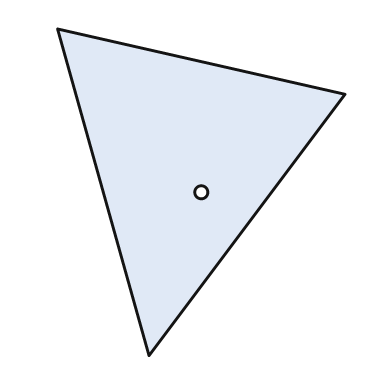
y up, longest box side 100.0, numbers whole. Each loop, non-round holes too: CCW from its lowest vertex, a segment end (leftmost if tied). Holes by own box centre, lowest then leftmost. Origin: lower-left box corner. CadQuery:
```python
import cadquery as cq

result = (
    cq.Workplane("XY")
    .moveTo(28.0, 0.0)
    .lineTo(88.0, 80.0)
    .lineTo(0.0, 100.0)
    .close()
    .moveTo(44.0, 50.0)
    .circle(2.0)
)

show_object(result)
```